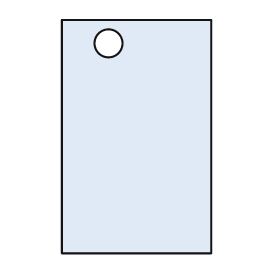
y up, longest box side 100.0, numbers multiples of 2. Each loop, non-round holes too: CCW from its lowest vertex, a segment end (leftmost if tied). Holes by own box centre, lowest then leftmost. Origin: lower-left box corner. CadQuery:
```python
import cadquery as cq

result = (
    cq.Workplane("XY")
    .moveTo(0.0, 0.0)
    .lineTo(64.0, 0.0)
    .lineTo(64.0, 100.0)
    .lineTo(0.0, 100.0)
    .close()
    .moveTo(20.0, 90.0)
    .circle(6.0)
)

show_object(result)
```